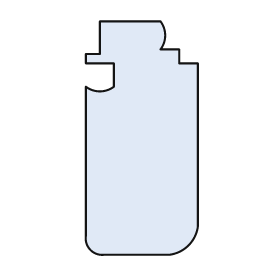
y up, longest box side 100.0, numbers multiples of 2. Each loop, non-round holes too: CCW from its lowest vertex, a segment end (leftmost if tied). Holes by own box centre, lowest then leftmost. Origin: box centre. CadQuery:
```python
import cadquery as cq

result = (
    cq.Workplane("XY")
    .moveTo(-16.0, -50.0)
    .lineTo(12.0, -50.0)
    .threePointArc((20.0, -46.0), (24.0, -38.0))
    .lineTo(24.0, 32.0)
    .lineTo(16.0, 32.0)
    .lineTo(16.0, 38.0)
    .lineTo(8.0, 38.0)
    .threePointArc((10.0, 44.0), (8.0, 50.0))
    .lineTo(-18.0, 50.0)
    .lineTo(-18.0, 36.0)
    .lineTo(-24.0, 36.0)
    .lineTo(-24.0, 32.0)
    .lineTo(-12.0, 32.0)
    .lineTo(-12.0, 22.0)
    .threePointArc((-18.0, 20.0), (-24.0, 22.0))
    .lineTo(-24.0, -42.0)
    .threePointArc((-22.0, -48.0), (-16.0, -50.0))
    .close()
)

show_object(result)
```